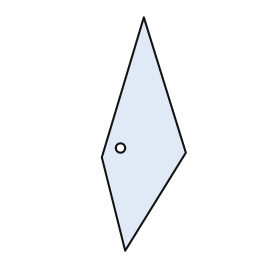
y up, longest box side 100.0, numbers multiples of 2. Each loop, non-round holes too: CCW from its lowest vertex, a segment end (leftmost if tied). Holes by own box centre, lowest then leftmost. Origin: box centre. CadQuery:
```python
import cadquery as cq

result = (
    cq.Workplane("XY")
    .moveTo(-8.0, -50.0)
    .lineTo(18.0, -8.0)
    .lineTo(0.0, 50.0)
    .lineTo(-18.0, -10.0)
    .close()
    .moveTo(-10.0, -6.0)
    .circle(2.0)
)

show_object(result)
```